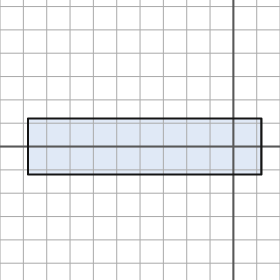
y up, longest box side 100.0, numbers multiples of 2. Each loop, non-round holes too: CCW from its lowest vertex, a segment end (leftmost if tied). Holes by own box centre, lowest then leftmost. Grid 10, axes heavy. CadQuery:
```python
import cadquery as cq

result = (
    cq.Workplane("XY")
    .moveTo(-88.0, -12.0)
    .lineTo(12.0, -12.0)
    .lineTo(12.0, 12.0)
    .lineTo(-88.0, 12.0)
    .close()
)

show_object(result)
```